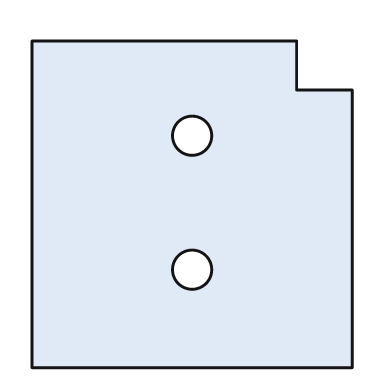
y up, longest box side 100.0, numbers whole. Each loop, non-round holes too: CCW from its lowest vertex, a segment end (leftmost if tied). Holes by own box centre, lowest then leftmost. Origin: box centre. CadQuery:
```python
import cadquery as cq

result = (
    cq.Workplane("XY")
    .moveTo(-49.0, -50.0)
    .lineTo(49.0, -50.0)
    .lineTo(49.0, 35.0)
    .lineTo(32.0, 35.0)
    .lineTo(32.0, 50.0)
    .lineTo(-49.0, 50.0)
    .close()
    .moveTo(0.0, -20.0)
    .circle(6.0)
    .moveTo(0.0, 21.0)
    .circle(6.0)
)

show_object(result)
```